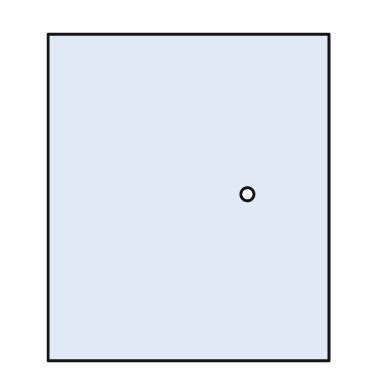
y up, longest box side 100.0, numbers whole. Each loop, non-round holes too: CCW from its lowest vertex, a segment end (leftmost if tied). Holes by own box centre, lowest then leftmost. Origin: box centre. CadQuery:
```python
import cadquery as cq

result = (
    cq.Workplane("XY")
    .moveTo(-43.0, -50.0)
    .lineTo(43.0, -50.0)
    .lineTo(43.0, 50.0)
    .lineTo(-43.0, 50.0)
    .close()
    .moveTo(18.0, 1.0)
    .circle(2.0)
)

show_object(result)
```